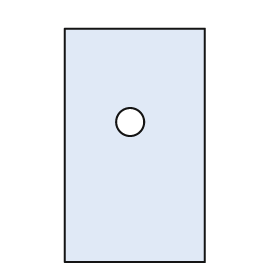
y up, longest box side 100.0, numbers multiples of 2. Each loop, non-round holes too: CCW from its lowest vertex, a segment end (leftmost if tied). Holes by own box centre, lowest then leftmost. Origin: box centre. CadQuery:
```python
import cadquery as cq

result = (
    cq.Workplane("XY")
    .moveTo(-30.0, -50.0)
    .lineTo(30.0, -50.0)
    .lineTo(30.0, 50.0)
    .lineTo(-30.0, 50.0)
    .close()
    .moveTo(-2.0, 10.0)
    .circle(6.0)
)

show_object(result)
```